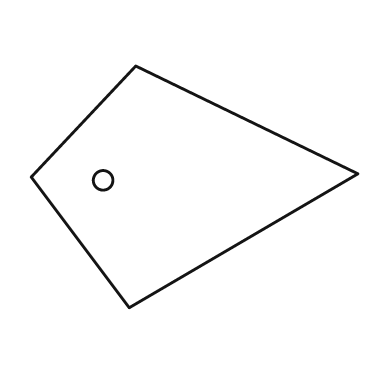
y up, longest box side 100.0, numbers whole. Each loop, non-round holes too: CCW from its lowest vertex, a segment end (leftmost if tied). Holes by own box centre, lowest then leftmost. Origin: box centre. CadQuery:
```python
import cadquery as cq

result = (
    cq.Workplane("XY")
    .moveTo(-20.0, -37.0)
    .lineTo(50.0, 4.0)
    .lineTo(-18.0, 37.0)
    .lineTo(-50.0, 3.0)
    .close()
    .moveTo(-28.0, 2.0)
    .circle(3.0)
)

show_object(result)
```